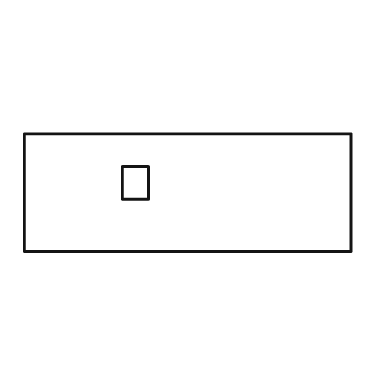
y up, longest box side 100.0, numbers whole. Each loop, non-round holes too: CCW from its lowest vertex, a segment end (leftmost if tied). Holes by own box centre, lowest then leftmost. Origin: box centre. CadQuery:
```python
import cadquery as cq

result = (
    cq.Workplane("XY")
    .moveTo(-50.0, -18.0)
    .lineTo(50.0, -18.0)
    .lineTo(50.0, 18.0)
    .lineTo(-50.0, 18.0)
    .close()
    .moveTo(-20.0, -2.0)
    .lineTo(-12.0, -2.0)
    .lineTo(-12.0, 8.0)
    .lineTo(-20.0, 8.0)
    .close()
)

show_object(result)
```